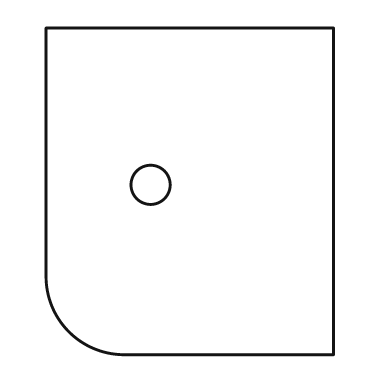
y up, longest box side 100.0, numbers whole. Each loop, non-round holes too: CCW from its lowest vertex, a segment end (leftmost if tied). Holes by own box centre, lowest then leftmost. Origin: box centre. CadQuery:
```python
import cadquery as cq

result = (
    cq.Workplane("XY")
    .moveTo(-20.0, -50.0)
    .lineTo(44.0, -50.0)
    .lineTo(44.0, 50.0)
    .lineTo(-44.0, 50.0)
    .lineTo(-44.0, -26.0)
    .threePointArc((-37.0, -43.0), (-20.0, -50.0))
    .close()
    .moveTo(-12.0, 2.0)
    .circle(6.0)
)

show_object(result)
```